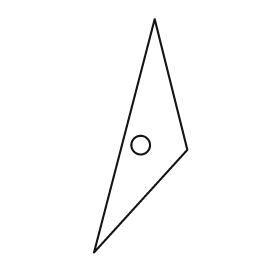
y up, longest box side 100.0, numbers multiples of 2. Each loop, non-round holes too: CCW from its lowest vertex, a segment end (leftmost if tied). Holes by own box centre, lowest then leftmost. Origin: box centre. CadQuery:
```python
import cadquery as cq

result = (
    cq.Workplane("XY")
    .moveTo(-20.0, -50.0)
    .lineTo(20.0, -6.0)
    .lineTo(6.0, 50.0)
    .close()
    .moveTo(0.0, -4.0)
    .circle(4.0)
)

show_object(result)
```